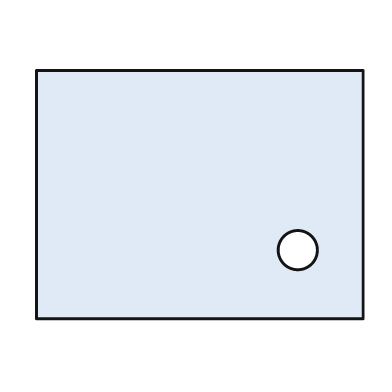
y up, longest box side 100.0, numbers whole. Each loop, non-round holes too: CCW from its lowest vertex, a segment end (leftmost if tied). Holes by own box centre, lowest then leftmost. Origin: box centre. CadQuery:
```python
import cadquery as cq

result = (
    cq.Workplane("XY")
    .moveTo(-50.0, -38.0)
    .lineTo(50.0, -38.0)
    .lineTo(50.0, 38.0)
    .lineTo(-50.0, 38.0)
    .close()
    .moveTo(30.0, -17.0)
    .circle(6.0)
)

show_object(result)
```